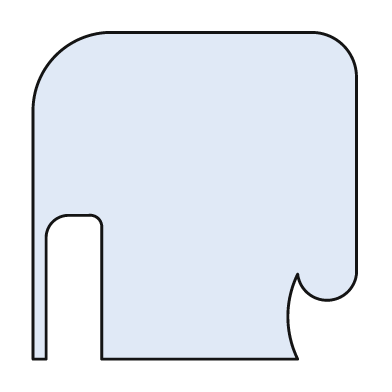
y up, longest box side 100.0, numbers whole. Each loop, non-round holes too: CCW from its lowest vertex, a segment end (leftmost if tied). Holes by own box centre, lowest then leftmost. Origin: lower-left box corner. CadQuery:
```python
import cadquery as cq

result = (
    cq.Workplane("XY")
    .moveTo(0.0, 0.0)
    .lineTo(4.0, 0.0)
    .lineTo(4.0, 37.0)
    .threePointArc((6.0, 42.0), (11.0, 44.0))
    .lineTo(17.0, 44.0)
    .threePointArc((20.0, 43.0), (21.0, 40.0))
    .lineTo(21.0, 0.0)
    .lineTo(81.0, 0.0)
    .threePointArc((78.0, 13.0), (81.0, 26.0))
    .threePointArc((90.0, 18.0), (99.0, 26.0))
    .lineTo(99.0, 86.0)
    .threePointArc((95.0, 96.0), (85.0, 100.0))
    .lineTo(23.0, 100.0)
    .threePointArc((7.0, 93.0), (0.0, 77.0))
    .close()
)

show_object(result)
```